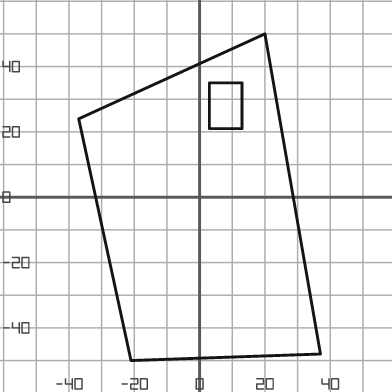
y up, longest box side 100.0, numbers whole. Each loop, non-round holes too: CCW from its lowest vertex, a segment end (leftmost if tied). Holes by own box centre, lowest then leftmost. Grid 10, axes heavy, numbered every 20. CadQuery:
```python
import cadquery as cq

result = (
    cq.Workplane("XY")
    .moveTo(-21.0, -50.0)
    .lineTo(37.0, -48.0)
    .lineTo(20.0, 50.0)
    .lineTo(-37.0, 24.0)
    .close()
    .moveTo(3.0, 21.0)
    .lineTo(13.0, 21.0)
    .lineTo(13.0, 35.0)
    .lineTo(3.0, 35.0)
    .close()
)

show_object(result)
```